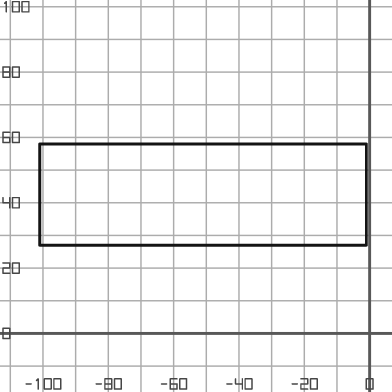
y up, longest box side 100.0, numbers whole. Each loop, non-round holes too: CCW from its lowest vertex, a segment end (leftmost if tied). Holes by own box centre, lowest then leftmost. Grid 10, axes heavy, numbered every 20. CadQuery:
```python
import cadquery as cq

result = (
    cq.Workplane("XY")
    .moveTo(-101.0, 27.0)
    .lineTo(-1.0, 27.0)
    .lineTo(-1.0, 58.0)
    .lineTo(-101.0, 58.0)
    .close()
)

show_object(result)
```